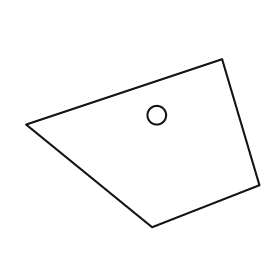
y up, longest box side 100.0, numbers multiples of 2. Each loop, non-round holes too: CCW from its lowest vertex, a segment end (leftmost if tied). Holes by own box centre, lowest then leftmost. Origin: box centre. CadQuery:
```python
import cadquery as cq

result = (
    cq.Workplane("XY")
    .moveTo(4.0, -36.0)
    .lineTo(50.0, -18.0)
    .lineTo(34.0, 36.0)
    .lineTo(-50.0, 8.0)
    .close()
    .moveTo(6.0, 12.0)
    .circle(4.0)
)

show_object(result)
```